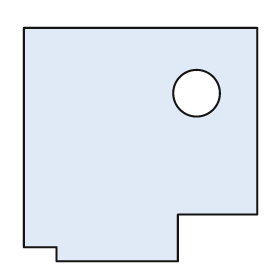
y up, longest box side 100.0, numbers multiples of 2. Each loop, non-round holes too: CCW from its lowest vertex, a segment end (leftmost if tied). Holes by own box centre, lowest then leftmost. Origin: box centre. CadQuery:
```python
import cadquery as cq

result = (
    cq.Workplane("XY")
    .moveTo(-36.0, -50.0)
    .lineTo(16.0, -50.0)
    .lineTo(16.0, -30.0)
    .lineTo(50.0, -30.0)
    .lineTo(50.0, 50.0)
    .lineTo(-50.0, 50.0)
    .lineTo(-50.0, -44.0)
    .lineTo(-36.0, -44.0)
    .close()
    .moveTo(24.0, 22.0)
    .circle(10.0)
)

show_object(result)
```